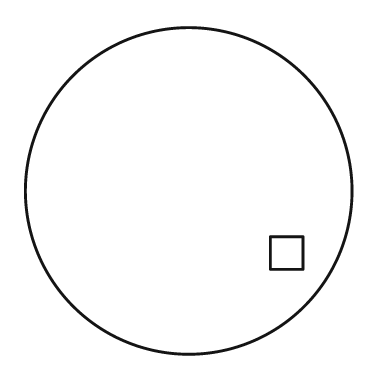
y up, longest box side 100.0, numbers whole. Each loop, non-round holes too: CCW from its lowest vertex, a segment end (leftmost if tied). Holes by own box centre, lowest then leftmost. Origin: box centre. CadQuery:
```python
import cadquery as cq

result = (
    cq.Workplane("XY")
    .moveTo(0.0, 0.0)
    .circle(50.0)
    .moveTo(25.0, -24.0)
    .lineTo(35.0, -24.0)
    .lineTo(35.0, -14.0)
    .lineTo(25.0, -14.0)
    .close()
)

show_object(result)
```